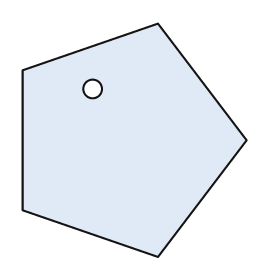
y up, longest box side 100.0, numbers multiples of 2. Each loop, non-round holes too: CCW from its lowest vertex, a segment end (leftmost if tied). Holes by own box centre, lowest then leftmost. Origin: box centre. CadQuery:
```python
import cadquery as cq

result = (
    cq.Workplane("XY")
    .moveTo(10.0, -50.0)
    .lineTo(48.0, 0.0)
    .lineTo(10.0, 50.0)
    .lineTo(-48.0, 30.0)
    .lineTo(-48.0, -30.0)
    .close()
    .moveTo(-18.0, 22.0)
    .circle(4.0)
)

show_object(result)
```